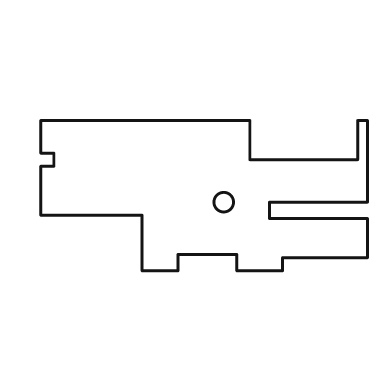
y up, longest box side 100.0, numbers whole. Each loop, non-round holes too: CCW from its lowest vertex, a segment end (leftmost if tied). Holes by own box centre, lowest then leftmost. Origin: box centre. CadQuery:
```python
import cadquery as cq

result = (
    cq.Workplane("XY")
    .moveTo(-19.0, -23.0)
    .lineTo(-8.0, -23.0)
    .lineTo(-8.0, -18.0)
    .lineTo(10.0, -18.0)
    .lineTo(10.0, -23.0)
    .lineTo(24.0, -23.0)
    .lineTo(24.0, -19.0)
    .lineTo(50.0, -19.0)
    .lineTo(50.0, -7.0)
    .lineTo(20.0, -7.0)
    .lineTo(20.0, -2.0)
    .lineTo(50.0, -2.0)
    .lineTo(50.0, 23.0)
    .lineTo(47.0, 23.0)
    .lineTo(47.0, 11.0)
    .lineTo(14.0, 11.0)
    .lineTo(14.0, 23.0)
    .lineTo(-50.0, 23.0)
    .lineTo(-50.0, 13.0)
    .lineTo(-46.0, 13.0)
    .lineTo(-46.0, 9.0)
    .lineTo(-50.0, 9.0)
    .lineTo(-50.0, -6.0)
    .lineTo(-19.0, -6.0)
    .close()
    .moveTo(6.0, -2.0)
    .circle(3.0)
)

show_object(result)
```